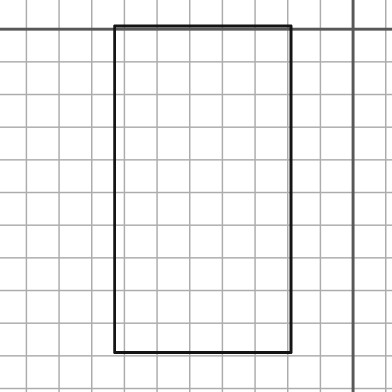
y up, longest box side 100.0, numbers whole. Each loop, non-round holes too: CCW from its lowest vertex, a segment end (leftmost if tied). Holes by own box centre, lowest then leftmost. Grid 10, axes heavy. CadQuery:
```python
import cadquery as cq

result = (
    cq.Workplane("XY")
    .moveTo(-73.0, -99.0)
    .lineTo(-19.0, -99.0)
    .lineTo(-19.0, 1.0)
    .lineTo(-73.0, 1.0)
    .close()
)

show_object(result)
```